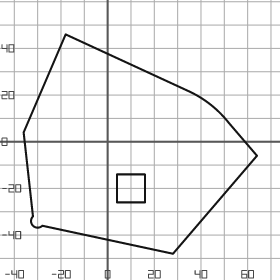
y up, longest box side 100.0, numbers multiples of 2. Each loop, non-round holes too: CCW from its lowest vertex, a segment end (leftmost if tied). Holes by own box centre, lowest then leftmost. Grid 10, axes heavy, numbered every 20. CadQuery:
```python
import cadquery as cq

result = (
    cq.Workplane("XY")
    .moveTo(28.0, -48.0)
    .lineTo(64.0, -6.0)
    .lineTo(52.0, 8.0)
    .threePointArc((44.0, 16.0), (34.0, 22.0))
    .lineTo(-18.0, 46.0)
    .lineTo(-36.0, 4.0)
    .lineTo(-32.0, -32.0)
    .threePointArc((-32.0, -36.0), (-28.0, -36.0))
    .close()
    .moveTo(4.0, -26.0)
    .lineTo(16.0, -26.0)
    .lineTo(16.0, -14.0)
    .lineTo(4.0, -14.0)
    .close()
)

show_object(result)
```